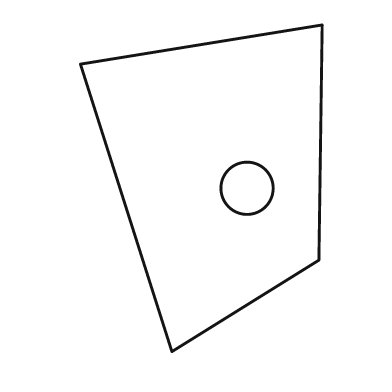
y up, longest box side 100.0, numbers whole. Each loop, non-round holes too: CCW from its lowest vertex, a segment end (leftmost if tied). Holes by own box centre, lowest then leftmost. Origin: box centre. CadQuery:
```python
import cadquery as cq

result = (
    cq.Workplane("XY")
    .moveTo(-9.0, -50.0)
    .lineTo(36.0, -22.0)
    .lineTo(37.0, 50.0)
    .lineTo(-37.0, 38.0)
    .close()
    .moveTo(14.0, 0.0)
    .circle(8.0)
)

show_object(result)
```